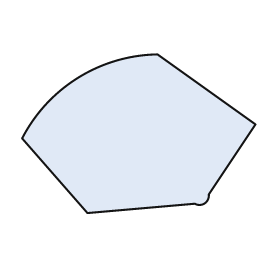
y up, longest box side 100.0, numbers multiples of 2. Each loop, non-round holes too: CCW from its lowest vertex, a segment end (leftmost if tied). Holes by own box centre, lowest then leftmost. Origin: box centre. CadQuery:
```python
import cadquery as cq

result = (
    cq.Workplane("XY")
    .moveTo(-22.0, -34.0)
    .lineTo(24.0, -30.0)
    .threePointArc((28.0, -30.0), (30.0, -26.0))
    .lineTo(50.0, 4.0)
    .lineTo(8.0, 34.0)
    .threePointArc((-26.0, 24.0), (-50.0, -2.0))
    .close()
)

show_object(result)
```